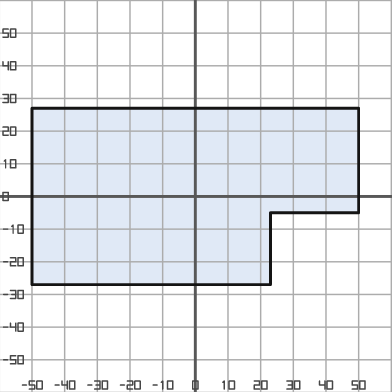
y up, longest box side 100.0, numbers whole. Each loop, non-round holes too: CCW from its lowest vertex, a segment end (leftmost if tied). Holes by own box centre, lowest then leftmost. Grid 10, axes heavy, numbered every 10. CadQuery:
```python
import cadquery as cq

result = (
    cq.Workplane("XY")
    .moveTo(-50.0, -27.0)
    .lineTo(23.0, -27.0)
    .lineTo(23.0, -5.0)
    .lineTo(50.0, -5.0)
    .lineTo(50.0, 27.0)
    .lineTo(-50.0, 27.0)
    .close()
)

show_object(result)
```